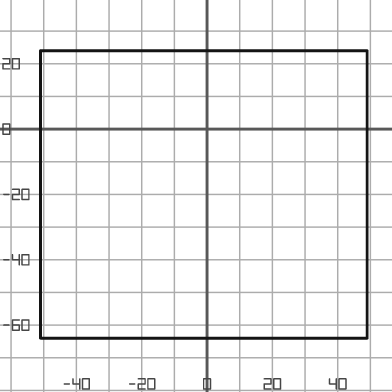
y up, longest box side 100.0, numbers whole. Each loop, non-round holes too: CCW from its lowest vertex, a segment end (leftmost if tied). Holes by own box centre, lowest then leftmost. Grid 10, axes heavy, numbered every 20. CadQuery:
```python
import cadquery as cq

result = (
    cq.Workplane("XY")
    .moveTo(-51.0, -64.0)
    .lineTo(49.0, -64.0)
    .lineTo(49.0, 24.0)
    .lineTo(-51.0, 24.0)
    .close()
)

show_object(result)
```